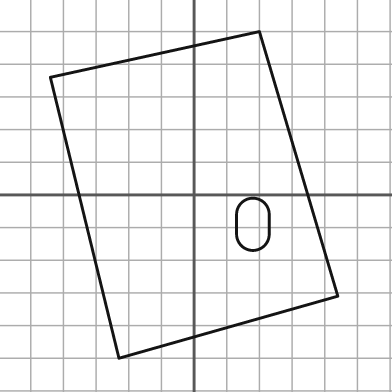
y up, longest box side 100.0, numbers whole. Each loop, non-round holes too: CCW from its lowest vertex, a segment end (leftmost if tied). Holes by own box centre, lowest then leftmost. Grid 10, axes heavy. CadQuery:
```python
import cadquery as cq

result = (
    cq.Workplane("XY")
    .moveTo(-23.0, -50.0)
    .lineTo(44.0, -31.0)
    .lineTo(20.0, 50.0)
    .lineTo(-44.0, 36.0)
    .close()
    .moveTo(13.0, -12.0)
    .threePointArc((18.0, -17.0), (23.0, -12.0))
    .lineTo(23.0, -6.0)
    .threePointArc((18.0, -1.0), (13.0, -6.0))
    .close()
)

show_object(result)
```